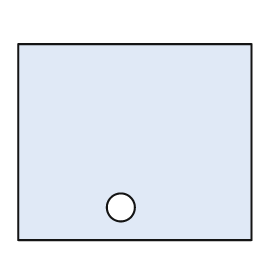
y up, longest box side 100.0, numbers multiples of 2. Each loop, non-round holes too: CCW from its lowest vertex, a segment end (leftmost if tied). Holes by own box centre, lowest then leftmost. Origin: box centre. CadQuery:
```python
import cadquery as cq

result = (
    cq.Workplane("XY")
    .moveTo(-50.0, -42.0)
    .lineTo(50.0, -42.0)
    .lineTo(50.0, 42.0)
    .lineTo(-50.0, 42.0)
    .close()
    .moveTo(-6.0, -28.0)
    .circle(6.0)
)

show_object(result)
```